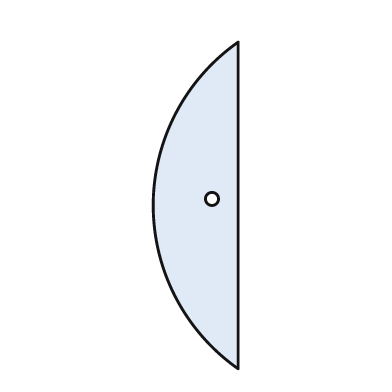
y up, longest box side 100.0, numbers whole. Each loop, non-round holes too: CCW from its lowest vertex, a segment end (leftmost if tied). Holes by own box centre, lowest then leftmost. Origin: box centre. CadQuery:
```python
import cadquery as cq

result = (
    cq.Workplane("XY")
    .moveTo(13.0, -50.0)
    .lineTo(13.0, 50.0)
    .threePointArc((-13.0, 0.0), (13.0, -50.0))
    .close()
    .moveTo(5.0, 2.0)
    .circle(2.0)
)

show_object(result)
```